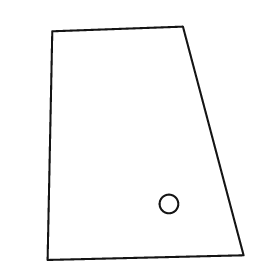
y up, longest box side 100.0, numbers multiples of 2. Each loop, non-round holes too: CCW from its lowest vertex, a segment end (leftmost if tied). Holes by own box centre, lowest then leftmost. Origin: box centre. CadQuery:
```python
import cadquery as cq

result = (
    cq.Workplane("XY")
    .moveTo(-42.0, -50.0)
    .lineTo(42.0, -48.0)
    .lineTo(16.0, 50.0)
    .lineTo(-40.0, 48.0)
    .close()
    .moveTo(10.0, -26.0)
    .circle(4.0)
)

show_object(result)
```